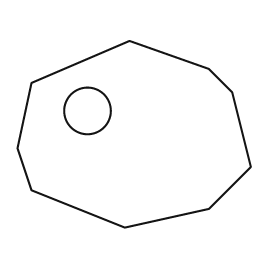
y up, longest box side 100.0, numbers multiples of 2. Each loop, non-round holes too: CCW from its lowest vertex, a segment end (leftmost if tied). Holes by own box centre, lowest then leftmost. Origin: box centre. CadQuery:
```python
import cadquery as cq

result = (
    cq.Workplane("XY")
    .moveTo(-4.0, -40.0)
    .lineTo(32.0, -32.0)
    .lineTo(50.0, -14.0)
    .lineTo(42.0, 18.0)
    .lineTo(32.0, 28.0)
    .lineTo(-2.0, 40.0)
    .lineTo(-44.0, 22.0)
    .lineTo(-50.0, -6.0)
    .lineTo(-44.0, -24.0)
    .close()
    .moveTo(-20.0, 10.0)
    .circle(10.0)
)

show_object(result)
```